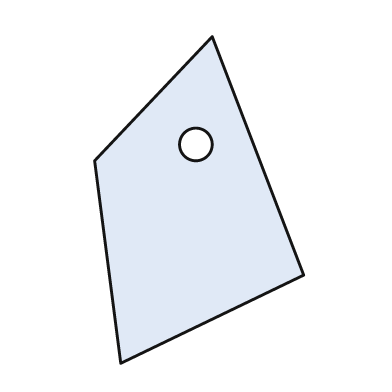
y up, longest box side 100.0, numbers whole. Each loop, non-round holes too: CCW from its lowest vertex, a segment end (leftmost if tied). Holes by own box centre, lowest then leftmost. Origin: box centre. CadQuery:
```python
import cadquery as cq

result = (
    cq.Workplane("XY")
    .moveTo(-24.0, -50.0)
    .lineTo(32.0, -23.0)
    .lineTo(4.0, 50.0)
    .lineTo(-32.0, 12.0)
    .close()
    .moveTo(-1.0, 17.0)
    .circle(5.0)
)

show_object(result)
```